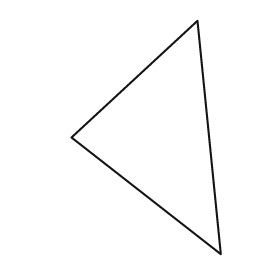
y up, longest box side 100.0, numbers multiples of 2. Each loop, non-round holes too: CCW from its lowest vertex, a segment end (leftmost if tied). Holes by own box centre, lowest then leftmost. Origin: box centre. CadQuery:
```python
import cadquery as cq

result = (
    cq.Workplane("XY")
    .moveTo(32.0, -50.0)
    .lineTo(22.0, 50.0)
    .lineTo(-32.0, 0.0)
    .close()
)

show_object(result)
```